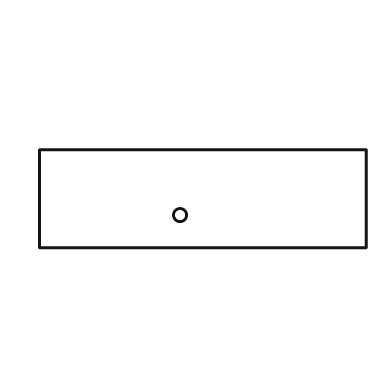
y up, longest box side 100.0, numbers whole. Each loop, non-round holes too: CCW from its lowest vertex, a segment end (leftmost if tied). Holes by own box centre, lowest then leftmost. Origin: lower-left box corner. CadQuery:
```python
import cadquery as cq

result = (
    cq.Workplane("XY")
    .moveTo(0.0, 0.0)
    .lineTo(100.0, 0.0)
    .lineTo(100.0, 30.0)
    .lineTo(0.0, 30.0)
    .close()
    .moveTo(43.0, 10.0)
    .circle(2.0)
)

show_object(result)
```